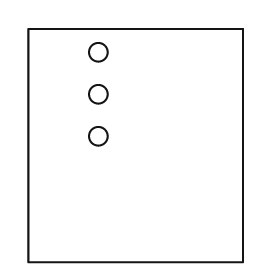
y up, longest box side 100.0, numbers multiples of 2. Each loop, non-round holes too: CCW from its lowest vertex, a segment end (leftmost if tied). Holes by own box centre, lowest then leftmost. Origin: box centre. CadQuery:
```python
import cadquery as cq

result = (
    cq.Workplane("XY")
    .moveTo(-46.0, -50.0)
    .lineTo(46.0, -50.0)
    .lineTo(46.0, 50.0)
    .lineTo(-46.0, 50.0)
    .close()
    .moveTo(-16.0, 4.0)
    .circle(4.0)
    .moveTo(-16.0, 22.0)
    .circle(4.0)
    .moveTo(-16.0, 40.0)
    .circle(4.0)
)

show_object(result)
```